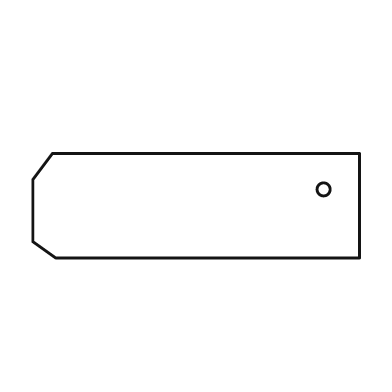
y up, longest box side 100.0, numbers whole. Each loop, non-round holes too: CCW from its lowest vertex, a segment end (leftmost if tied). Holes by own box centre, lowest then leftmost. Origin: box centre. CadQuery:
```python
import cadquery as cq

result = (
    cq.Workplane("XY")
    .moveTo(-43.0, -16.0)
    .lineTo(50.0, -16.0)
    .lineTo(50.0, 16.0)
    .lineTo(-44.0, 16.0)
    .lineTo(-50.0, 8.0)
    .lineTo(-50.0, -11.0)
    .close()
    .moveTo(39.0, 5.0)
    .circle(2.0)
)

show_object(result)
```